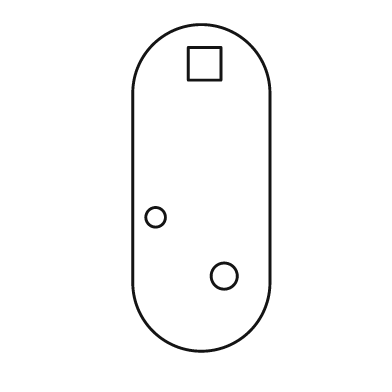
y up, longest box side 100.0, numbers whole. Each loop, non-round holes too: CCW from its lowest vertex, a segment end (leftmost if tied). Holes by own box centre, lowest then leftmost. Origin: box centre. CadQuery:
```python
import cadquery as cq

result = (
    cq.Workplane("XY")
    .moveTo(-21.0, -29.0)
    .threePointArc((0.0, -50.0), (21.0, -29.0))
    .lineTo(21.0, 29.0)
    .threePointArc((0.0, 50.0), (-21.0, 29.0))
    .close()
    .moveTo(7.0, -27.0)
    .circle(4.0)
    .moveTo(-14.0, -9.0)
    .circle(3.0)
    .moveTo(-4.0, 33.0)
    .lineTo(6.0, 33.0)
    .lineTo(6.0, 43.0)
    .lineTo(-4.0, 43.0)
    .close()
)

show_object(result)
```